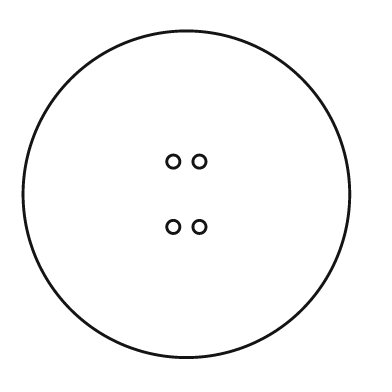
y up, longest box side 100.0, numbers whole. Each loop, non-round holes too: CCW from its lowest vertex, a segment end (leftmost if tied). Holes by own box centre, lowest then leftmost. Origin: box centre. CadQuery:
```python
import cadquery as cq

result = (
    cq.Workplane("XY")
    .moveTo(0.0, 0.0)
    .circle(50.0)
    .moveTo(-4.0, -10.0)
    .circle(2.0)
    .moveTo(4.0, -10.0)
    .circle(2.0)
    .moveTo(-4.0, 10.0)
    .circle(2.0)
    .moveTo(4.0, 10.0)
    .circle(2.0)
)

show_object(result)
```